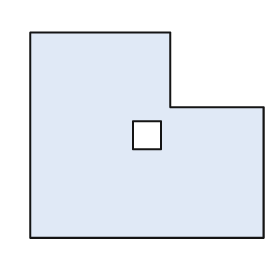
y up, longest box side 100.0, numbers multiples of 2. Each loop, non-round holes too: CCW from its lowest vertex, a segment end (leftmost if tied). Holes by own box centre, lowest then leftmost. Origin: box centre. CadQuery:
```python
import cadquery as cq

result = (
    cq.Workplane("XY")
    .moveTo(-50.0, -44.0)
    .lineTo(50.0, -44.0)
    .lineTo(50.0, 12.0)
    .lineTo(10.0, 12.0)
    .lineTo(10.0, 44.0)
    .lineTo(-50.0, 44.0)
    .close()
    .moveTo(-6.0, -6.0)
    .lineTo(6.0, -6.0)
    .lineTo(6.0, 6.0)
    .lineTo(-6.0, 6.0)
    .close()
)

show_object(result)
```